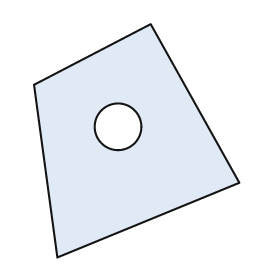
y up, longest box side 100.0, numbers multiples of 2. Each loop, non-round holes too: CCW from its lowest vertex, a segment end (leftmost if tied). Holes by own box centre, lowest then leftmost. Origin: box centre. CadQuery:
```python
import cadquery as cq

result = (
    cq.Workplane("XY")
    .moveTo(-34.0, -50.0)
    .lineTo(44.0, -18.0)
    .lineTo(6.0, 50.0)
    .lineTo(-44.0, 24.0)
    .close()
    .moveTo(-8.0, 6.0)
    .circle(10.0)
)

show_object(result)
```